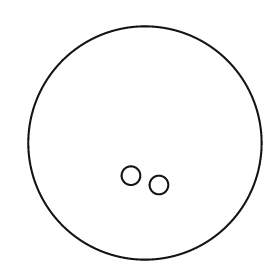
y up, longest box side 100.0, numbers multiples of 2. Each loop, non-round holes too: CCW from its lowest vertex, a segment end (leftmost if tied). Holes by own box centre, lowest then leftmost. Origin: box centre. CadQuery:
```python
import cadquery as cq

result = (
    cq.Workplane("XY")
    .moveTo(0.0, 0.0)
    .circle(50.0)
    .moveTo(6.0, -18.0)
    .circle(4.0)
    .moveTo(-6.0, -14.0)
    .circle(4.0)
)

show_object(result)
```